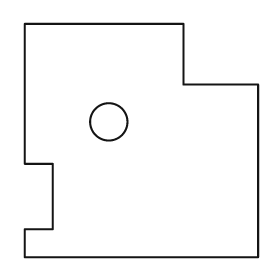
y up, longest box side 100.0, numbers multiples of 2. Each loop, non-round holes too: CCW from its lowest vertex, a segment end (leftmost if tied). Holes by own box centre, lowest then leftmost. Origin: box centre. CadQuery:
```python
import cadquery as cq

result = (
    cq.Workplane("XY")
    .moveTo(-50.0, -50.0)
    .lineTo(50.0, -50.0)
    .lineTo(50.0, 24.0)
    .lineTo(18.0, 24.0)
    .lineTo(18.0, 50.0)
    .lineTo(-50.0, 50.0)
    .lineTo(-50.0, -10.0)
    .lineTo(-38.0, -10.0)
    .lineTo(-38.0, -38.0)
    .lineTo(-50.0, -38.0)
    .close()
    .moveTo(-14.0, 8.0)
    .circle(8.0)
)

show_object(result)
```